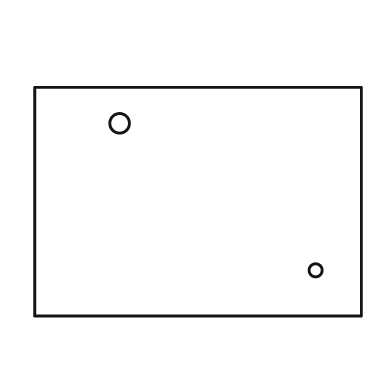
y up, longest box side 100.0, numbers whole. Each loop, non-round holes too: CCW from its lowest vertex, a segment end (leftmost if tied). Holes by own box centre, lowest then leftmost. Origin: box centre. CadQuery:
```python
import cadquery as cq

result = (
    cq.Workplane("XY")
    .moveTo(-50.0, -35.0)
    .lineTo(50.0, -35.0)
    .lineTo(50.0, 35.0)
    .lineTo(-50.0, 35.0)
    .close()
    .moveTo(36.0, -21.0)
    .circle(2.0)
    .moveTo(-24.0, 24.0)
    .circle(3.0)
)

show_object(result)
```